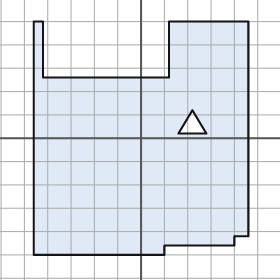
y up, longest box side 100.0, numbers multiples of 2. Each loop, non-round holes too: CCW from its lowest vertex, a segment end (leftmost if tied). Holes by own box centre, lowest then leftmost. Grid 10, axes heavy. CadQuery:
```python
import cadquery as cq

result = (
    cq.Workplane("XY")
    .moveTo(-46.0, -50.0)
    .lineTo(10.0, -50.0)
    .lineTo(10.0, -46.0)
    .lineTo(40.0, -46.0)
    .lineTo(40.0, -42.0)
    .lineTo(46.0, -42.0)
    .lineTo(46.0, 50.0)
    .lineTo(12.0, 50.0)
    .lineTo(12.0, 26.0)
    .lineTo(-42.0, 26.0)
    .lineTo(-42.0, 50.0)
    .lineTo(-46.0, 50.0)
    .close()
    .moveTo(16.0, 2.0)
    .lineTo(28.0, 2.0)
    .lineTo(22.0, 12.0)
    .close()
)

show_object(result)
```